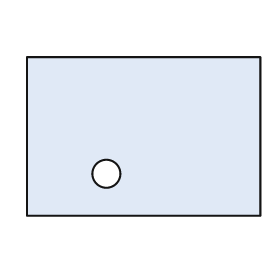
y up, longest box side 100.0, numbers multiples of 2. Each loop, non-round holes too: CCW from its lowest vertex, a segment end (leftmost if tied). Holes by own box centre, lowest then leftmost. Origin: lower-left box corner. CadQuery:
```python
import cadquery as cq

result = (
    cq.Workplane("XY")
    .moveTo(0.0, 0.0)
    .lineTo(100.0, 0.0)
    .lineTo(100.0, 68.0)
    .lineTo(0.0, 68.0)
    .close()
    .moveTo(34.0, 18.0)
    .circle(6.0)
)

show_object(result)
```